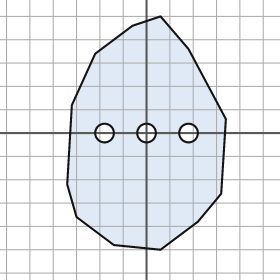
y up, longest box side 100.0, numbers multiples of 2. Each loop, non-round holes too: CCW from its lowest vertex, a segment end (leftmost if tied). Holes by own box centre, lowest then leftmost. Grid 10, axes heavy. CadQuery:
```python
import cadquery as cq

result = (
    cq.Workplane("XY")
    .moveTo(6.0, -50.0)
    .lineTo(22.0, -38.0)
    .lineTo(32.0, -26.0)
    .lineTo(34.0, 6.0)
    .lineTo(18.0, 36.0)
    .lineTo(6.0, 50.0)
    .lineTo(-6.0, 46.0)
    .lineTo(-22.0, 34.0)
    .lineTo(-32.0, 12.0)
    .lineTo(-34.0, -22.0)
    .lineTo(-30.0, -36.0)
    .lineTo(-14.0, -48.0)
    .close()
    .moveTo(-18.0, 0.0)
    .circle(4.0)
    .moveTo(0.0, 0.0)
    .circle(4.0)
    .moveTo(18.0, 0.0)
    .circle(4.0)
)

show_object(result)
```